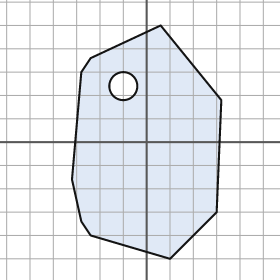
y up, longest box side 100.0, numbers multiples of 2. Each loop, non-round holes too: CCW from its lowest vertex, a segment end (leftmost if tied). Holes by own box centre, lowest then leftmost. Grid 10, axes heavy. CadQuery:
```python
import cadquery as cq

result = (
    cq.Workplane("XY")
    .moveTo(10.0, -50.0)
    .lineTo(30.0, -30.0)
    .lineTo(32.0, 18.0)
    .lineTo(6.0, 50.0)
    .lineTo(-24.0, 36.0)
    .lineTo(-28.0, 30.0)
    .lineTo(-32.0, -16.0)
    .lineTo(-28.0, -34.0)
    .lineTo(-24.0, -40.0)
    .close()
    .moveTo(-10.0, 24.0)
    .circle(6.0)
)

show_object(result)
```